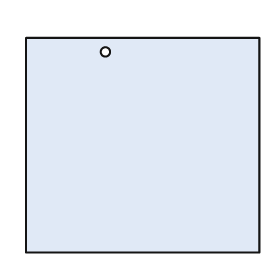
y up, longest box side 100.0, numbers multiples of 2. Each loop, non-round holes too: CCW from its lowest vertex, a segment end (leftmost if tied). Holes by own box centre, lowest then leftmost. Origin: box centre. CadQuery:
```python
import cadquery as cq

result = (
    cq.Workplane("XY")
    .moveTo(-50.0, -46.0)
    .lineTo(50.0, -46.0)
    .lineTo(50.0, 46.0)
    .lineTo(-50.0, 46.0)
    .close()
    .moveTo(-16.0, 40.0)
    .circle(2.0)
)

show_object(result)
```